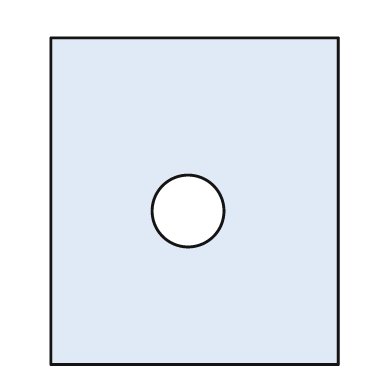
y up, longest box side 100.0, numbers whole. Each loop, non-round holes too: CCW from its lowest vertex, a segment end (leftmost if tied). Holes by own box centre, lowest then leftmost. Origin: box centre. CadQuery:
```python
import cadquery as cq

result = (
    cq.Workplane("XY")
    .moveTo(-44.0, -50.0)
    .lineTo(44.0, -50.0)
    .lineTo(44.0, 50.0)
    .lineTo(-44.0, 50.0)
    .close()
    .moveTo(-2.0, -3.0)
    .circle(11.0)
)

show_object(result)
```